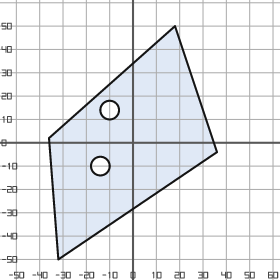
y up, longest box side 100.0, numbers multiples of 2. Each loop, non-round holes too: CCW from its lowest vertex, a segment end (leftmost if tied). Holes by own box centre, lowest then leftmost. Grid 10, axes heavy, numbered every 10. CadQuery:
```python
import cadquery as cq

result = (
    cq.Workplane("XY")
    .moveTo(-32.0, -50.0)
    .lineTo(36.0, -4.0)
    .lineTo(18.0, 50.0)
    .lineTo(-36.0, 2.0)
    .close()
    .moveTo(-14.0, -10.0)
    .circle(4.0)
    .moveTo(-10.0, 14.0)
    .circle(4.0)
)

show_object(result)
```